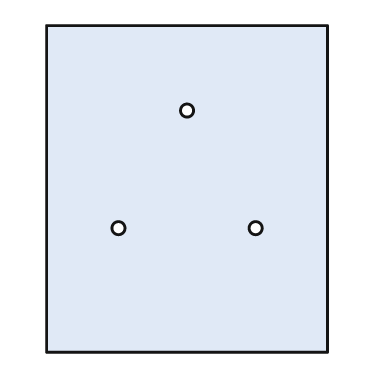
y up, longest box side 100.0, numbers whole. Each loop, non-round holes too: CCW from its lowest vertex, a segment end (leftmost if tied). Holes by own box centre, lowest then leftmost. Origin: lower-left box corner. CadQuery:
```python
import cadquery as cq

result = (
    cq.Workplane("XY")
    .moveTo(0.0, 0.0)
    .lineTo(86.0, 0.0)
    .lineTo(86.0, 100.0)
    .lineTo(0.0, 100.0)
    .close()
    .moveTo(22.0, 38.0)
    .circle(2.0)
    .moveTo(64.0, 38.0)
    .circle(2.0)
    .moveTo(43.0, 74.0)
    .circle(2.0)
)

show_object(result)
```